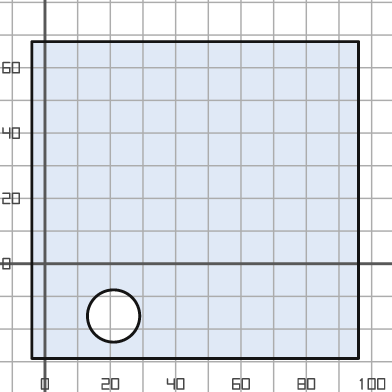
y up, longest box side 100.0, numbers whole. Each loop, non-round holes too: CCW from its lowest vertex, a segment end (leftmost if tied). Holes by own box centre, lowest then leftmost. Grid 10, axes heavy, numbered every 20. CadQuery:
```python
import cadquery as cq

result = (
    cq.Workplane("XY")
    .moveTo(-4.0, -29.0)
    .lineTo(96.0, -29.0)
    .lineTo(96.0, 68.0)
    .lineTo(-4.0, 68.0)
    .close()
    .moveTo(21.0, -16.0)
    .circle(8.0)
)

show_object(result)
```